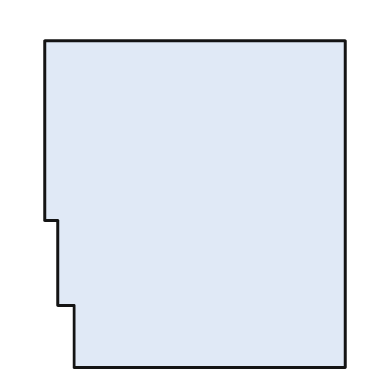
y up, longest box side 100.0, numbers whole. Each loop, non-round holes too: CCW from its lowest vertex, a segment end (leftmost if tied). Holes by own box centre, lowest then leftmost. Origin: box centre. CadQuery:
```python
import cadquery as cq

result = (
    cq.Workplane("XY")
    .moveTo(-37.0, -50.0)
    .lineTo(46.0, -50.0)
    .lineTo(46.0, 50.0)
    .lineTo(-46.0, 50.0)
    .lineTo(-46.0, -5.0)
    .lineTo(-42.0, -5.0)
    .lineTo(-42.0, -31.0)
    .lineTo(-37.0, -31.0)
    .close()
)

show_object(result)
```